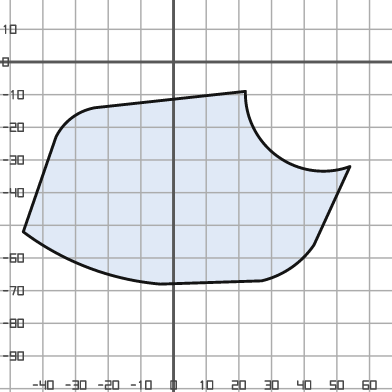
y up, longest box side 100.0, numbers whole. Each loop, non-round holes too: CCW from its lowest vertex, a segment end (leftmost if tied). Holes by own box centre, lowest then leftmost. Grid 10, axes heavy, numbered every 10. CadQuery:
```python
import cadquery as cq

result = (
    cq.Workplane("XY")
    .moveTo(-4.0, -68.0)
    .lineTo(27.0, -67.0)
    .threePointArc((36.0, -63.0), (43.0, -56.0))
    .lineTo(54.0, -32.0)
    .threePointArc((32.0, -29.0), (22.0, -9.0))
    .lineTo(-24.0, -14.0)
    .threePointArc((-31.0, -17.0), (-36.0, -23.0))
    .lineTo(-46.0, -52.0)
    .threePointArc((-26.0, -63.0), (-4.0, -68.0))
    .close()
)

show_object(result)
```